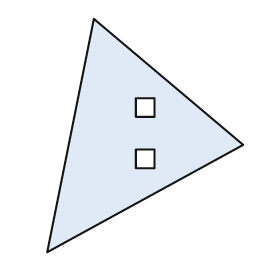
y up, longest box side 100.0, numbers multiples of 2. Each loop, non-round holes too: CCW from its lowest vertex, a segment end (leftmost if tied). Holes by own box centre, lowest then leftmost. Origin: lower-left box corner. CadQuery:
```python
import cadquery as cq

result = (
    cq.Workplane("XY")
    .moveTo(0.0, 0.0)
    .lineTo(84.0, 46.0)
    .lineTo(20.0, 100.0)
    .close()
    .moveTo(38.0, 36.0)
    .lineTo(46.0, 36.0)
    .lineTo(46.0, 44.0)
    .lineTo(38.0, 44.0)
    .close()
    .moveTo(38.0, 58.0)
    .lineTo(46.0, 58.0)
    .lineTo(46.0, 66.0)
    .lineTo(38.0, 66.0)
    .close()
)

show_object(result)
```